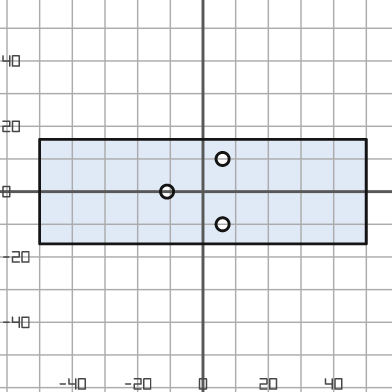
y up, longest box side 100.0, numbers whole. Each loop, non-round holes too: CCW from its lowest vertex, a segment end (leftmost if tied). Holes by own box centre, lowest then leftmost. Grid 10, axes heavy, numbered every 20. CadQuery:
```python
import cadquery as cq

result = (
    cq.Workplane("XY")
    .moveTo(-50.0, -16.0)
    .lineTo(50.0, -16.0)
    .lineTo(50.0, 16.0)
    .lineTo(-50.0, 16.0)
    .close()
    .moveTo(6.0, -10.0)
    .circle(2.0)
    .moveTo(-11.0, 0.0)
    .circle(2.0)
    .moveTo(6.0, 10.0)
    .circle(2.0)
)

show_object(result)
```